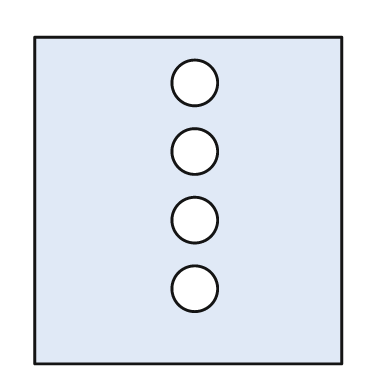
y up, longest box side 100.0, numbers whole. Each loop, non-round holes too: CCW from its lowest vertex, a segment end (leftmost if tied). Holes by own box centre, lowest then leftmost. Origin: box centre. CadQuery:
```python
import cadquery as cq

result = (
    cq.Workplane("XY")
    .moveTo(-47.0, -50.0)
    .lineTo(47.0, -50.0)
    .lineTo(47.0, 50.0)
    .lineTo(-47.0, 50.0)
    .close()
    .moveTo(2.0, -27.0)
    .circle(7.0)
    .moveTo(2.0, -6.0)
    .circle(7.0)
    .moveTo(2.0, 15.0)
    .circle(7.0)
    .moveTo(2.0, 36.0)
    .circle(7.0)
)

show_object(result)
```